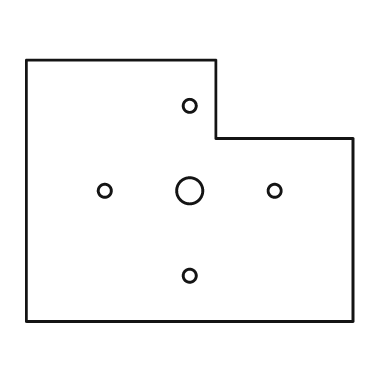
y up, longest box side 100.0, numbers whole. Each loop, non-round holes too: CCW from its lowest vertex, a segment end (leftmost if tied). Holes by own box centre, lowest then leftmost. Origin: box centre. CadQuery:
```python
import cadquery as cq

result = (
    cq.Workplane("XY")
    .moveTo(-50.0, -40.0)
    .lineTo(50.0, -40.0)
    .lineTo(50.0, 16.0)
    .lineTo(8.0, 16.0)
    .lineTo(8.0, 40.0)
    .lineTo(-50.0, 40.0)
    .close()
    .moveTo(0.0, -26.0)
    .circle(2.0)
    .moveTo(-26.0, 0.0)
    .circle(2.0)
    .moveTo(0.0, 0.0)
    .circle(4.0)
    .moveTo(26.0, 0.0)
    .circle(2.0)
    .moveTo(0.0, 26.0)
    .circle(2.0)
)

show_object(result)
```